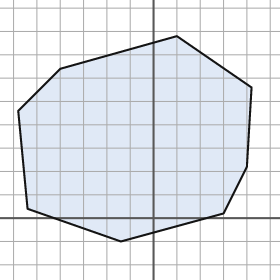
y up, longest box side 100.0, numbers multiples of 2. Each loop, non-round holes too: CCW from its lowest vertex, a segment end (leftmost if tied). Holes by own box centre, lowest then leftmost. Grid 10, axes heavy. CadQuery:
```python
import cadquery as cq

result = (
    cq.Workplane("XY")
    .moveTo(-14.0, -10.0)
    .lineTo(30.0, 2.0)
    .lineTo(40.0, 22.0)
    .lineTo(42.0, 56.0)
    .lineTo(10.0, 78.0)
    .lineTo(-40.0, 64.0)
    .lineTo(-58.0, 46.0)
    .lineTo(-54.0, 4.0)
    .close()
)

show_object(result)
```